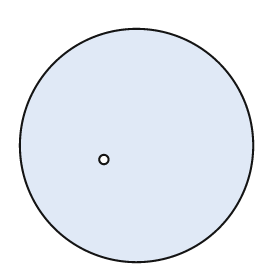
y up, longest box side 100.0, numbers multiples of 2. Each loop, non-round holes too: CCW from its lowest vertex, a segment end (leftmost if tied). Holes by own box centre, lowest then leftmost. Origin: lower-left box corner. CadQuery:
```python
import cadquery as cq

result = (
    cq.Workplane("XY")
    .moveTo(50.0, 50.0)
    .circle(50.0)
    .moveTo(36.0, 44.0)
    .circle(2.0)
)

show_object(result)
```